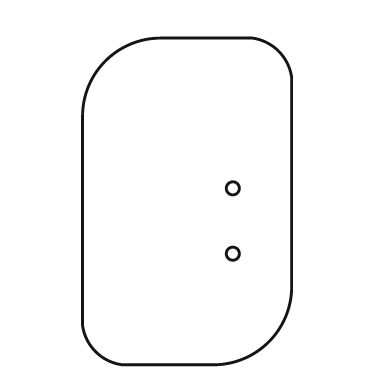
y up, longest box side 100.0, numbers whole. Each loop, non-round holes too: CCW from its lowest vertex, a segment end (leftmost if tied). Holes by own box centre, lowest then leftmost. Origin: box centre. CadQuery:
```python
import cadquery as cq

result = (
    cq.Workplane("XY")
    .moveTo(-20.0, -50.0)
    .lineTo(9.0, -50.0)
    .threePointArc((25.0, -43.0), (32.0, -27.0))
    .lineTo(32.0, 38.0)
    .threePointArc((28.0, 46.0), (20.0, 50.0))
    .lineTo(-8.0, 50.0)
    .threePointArc((-25.0, 43.0), (-32.0, 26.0))
    .lineTo(-32.0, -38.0)
    .threePointArc((-28.0, -46.0), (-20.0, -50.0))
    .close()
    .moveTo(14.0, -16.0)
    .circle(2.0)
    .moveTo(14.0, 4.0)
    .circle(2.0)
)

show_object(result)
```